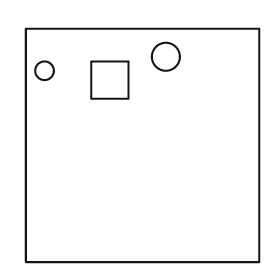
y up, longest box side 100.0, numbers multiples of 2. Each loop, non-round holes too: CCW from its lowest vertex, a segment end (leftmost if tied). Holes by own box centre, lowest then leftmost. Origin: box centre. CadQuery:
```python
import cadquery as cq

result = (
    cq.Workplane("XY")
    .moveTo(-50.0, -50.0)
    .lineTo(50.0, -50.0)
    .lineTo(50.0, 50.0)
    .lineTo(-50.0, 50.0)
    .close()
    .moveTo(-22.0, 20.0)
    .lineTo(-6.0, 20.0)
    .lineTo(-6.0, 36.0)
    .lineTo(-22.0, 36.0)
    .close()
    .moveTo(-42.0, 32.0)
    .circle(4.0)
    .moveTo(10.0, 38.0)
    .circle(6.0)
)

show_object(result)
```